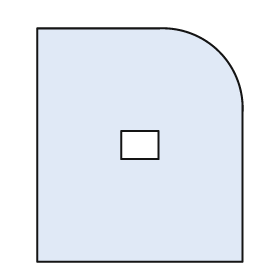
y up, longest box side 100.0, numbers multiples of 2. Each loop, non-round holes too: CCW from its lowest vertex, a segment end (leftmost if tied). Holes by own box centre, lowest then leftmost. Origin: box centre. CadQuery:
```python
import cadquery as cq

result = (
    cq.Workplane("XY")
    .moveTo(-44.0, -50.0)
    .lineTo(44.0, -50.0)
    .lineTo(44.0, 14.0)
    .threePointArc((34.0, 40.0), (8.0, 50.0))
    .lineTo(-44.0, 50.0)
    .close()
    .moveTo(-8.0, -6.0)
    .lineTo(8.0, -6.0)
    .lineTo(8.0, 6.0)
    .lineTo(-8.0, 6.0)
    .close()
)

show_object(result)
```